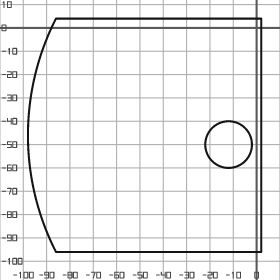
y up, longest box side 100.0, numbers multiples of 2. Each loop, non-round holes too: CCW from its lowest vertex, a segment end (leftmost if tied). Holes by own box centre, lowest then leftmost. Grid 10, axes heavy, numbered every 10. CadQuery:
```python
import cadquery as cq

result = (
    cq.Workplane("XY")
    .moveTo(-86.0, -96.0)
    .lineTo(2.0, -96.0)
    .lineTo(2.0, 4.0)
    .lineTo(-86.0, 4.0)
    .threePointArc((-98.0, -46.0), (-86.0, -96.0))
    .close()
    .moveTo(-12.0, -50.0)
    .circle(10.0)
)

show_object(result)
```